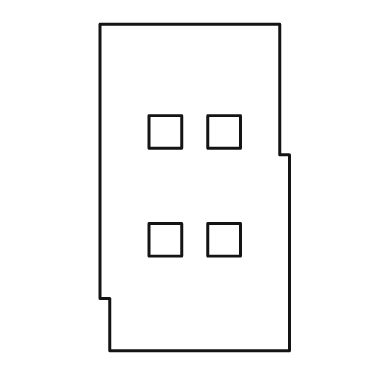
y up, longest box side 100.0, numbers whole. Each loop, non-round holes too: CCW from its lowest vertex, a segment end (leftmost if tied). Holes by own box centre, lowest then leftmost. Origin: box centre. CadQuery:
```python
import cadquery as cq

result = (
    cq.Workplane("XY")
    .moveTo(-26.0, -50.0)
    .lineTo(29.0, -50.0)
    .lineTo(29.0, 10.0)
    .lineTo(26.0, 10.0)
    .lineTo(26.0, 50.0)
    .lineTo(-29.0, 50.0)
    .lineTo(-29.0, -34.0)
    .lineTo(-26.0, -34.0)
    .close()
    .moveTo(-14.0, -21.0)
    .lineTo(-4.0, -21.0)
    .lineTo(-4.0, -11.0)
    .lineTo(-14.0, -11.0)
    .close()
    .moveTo(4.0, -21.0)
    .lineTo(14.0, -21.0)
    .lineTo(14.0, -11.0)
    .lineTo(4.0, -11.0)
    .close()
    .moveTo(-14.0, 12.0)
    .lineTo(-4.0, 12.0)
    .lineTo(-4.0, 22.0)
    .lineTo(-14.0, 22.0)
    .close()
    .moveTo(4.0, 12.0)
    .lineTo(14.0, 12.0)
    .lineTo(14.0, 22.0)
    .lineTo(4.0, 22.0)
    .close()
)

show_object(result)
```